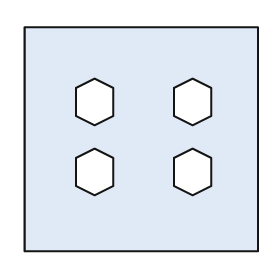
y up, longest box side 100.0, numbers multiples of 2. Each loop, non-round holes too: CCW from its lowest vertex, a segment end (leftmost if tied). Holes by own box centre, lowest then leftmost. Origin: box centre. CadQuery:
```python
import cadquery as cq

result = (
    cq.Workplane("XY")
    .moveTo(-50.0, -48.0)
    .lineTo(50.0, -48.0)
    .lineTo(50.0, 48.0)
    .lineTo(-50.0, 48.0)
    .close()
    .moveTo(-20.0, -24.0)
    .lineTo(-12.0, -20.0)
    .lineTo(-12.0, -8.0)
    .lineTo(-20.0, -4.0)
    .lineTo(-28.0, -8.0)
    .lineTo(-28.0, -20.0)
    .close()
    .moveTo(22.0, -24.0)
    .lineTo(30.0, -20.0)
    .lineTo(30.0, -8.0)
    .lineTo(22.0, -4.0)
    .lineTo(14.0, -8.0)
    .lineTo(14.0, -20.0)
    .close()
    .moveTo(-20.0, 6.0)
    .lineTo(-12.0, 10.0)
    .lineTo(-12.0, 22.0)
    .lineTo(-20.0, 26.0)
    .lineTo(-28.0, 22.0)
    .lineTo(-28.0, 10.0)
    .close()
    .moveTo(22.0, 6.0)
    .lineTo(30.0, 10.0)
    .lineTo(30.0, 22.0)
    .lineTo(22.0, 26.0)
    .lineTo(14.0, 22.0)
    .lineTo(14.0, 10.0)
    .close()
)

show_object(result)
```